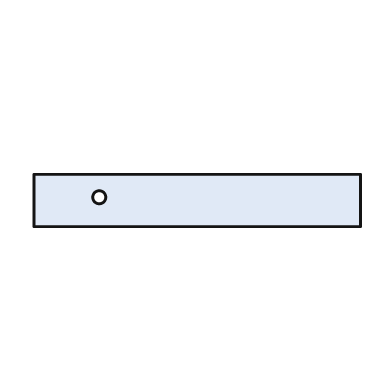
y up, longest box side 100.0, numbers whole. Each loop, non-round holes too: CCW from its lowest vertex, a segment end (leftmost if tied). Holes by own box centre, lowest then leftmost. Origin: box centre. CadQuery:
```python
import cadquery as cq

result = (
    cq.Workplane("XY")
    .moveTo(-50.0, -8.0)
    .lineTo(50.0, -8.0)
    .lineTo(50.0, 8.0)
    .lineTo(-50.0, 8.0)
    .close()
    .moveTo(-30.0, 1.0)
    .circle(2.0)
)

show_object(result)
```